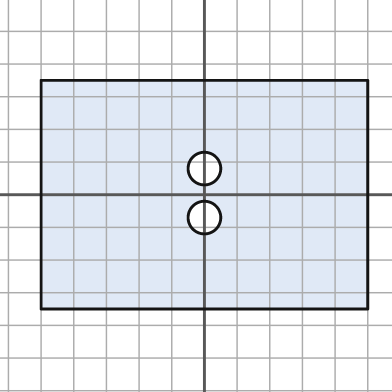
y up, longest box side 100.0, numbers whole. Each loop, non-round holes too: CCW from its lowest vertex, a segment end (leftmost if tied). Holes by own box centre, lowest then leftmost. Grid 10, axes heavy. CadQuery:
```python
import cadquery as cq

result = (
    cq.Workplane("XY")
    .moveTo(-50.0, -35.0)
    .lineTo(50.0, -35.0)
    .lineTo(50.0, 35.0)
    .lineTo(-50.0, 35.0)
    .close()
    .moveTo(0.0, -7.0)
    .circle(5.0)
    .moveTo(0.0, 8.0)
    .circle(5.0)
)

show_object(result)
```